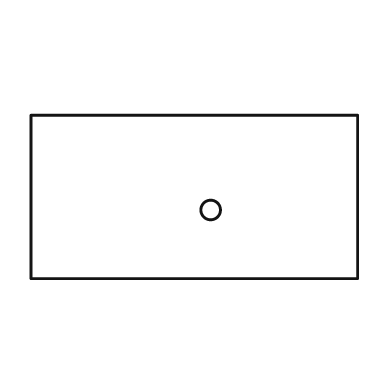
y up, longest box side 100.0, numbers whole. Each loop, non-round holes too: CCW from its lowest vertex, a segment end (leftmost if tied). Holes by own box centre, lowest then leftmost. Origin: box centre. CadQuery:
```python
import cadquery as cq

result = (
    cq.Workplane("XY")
    .moveTo(-50.0, -25.0)
    .lineTo(50.0, -25.0)
    .lineTo(50.0, 25.0)
    .lineTo(-50.0, 25.0)
    .close()
    .moveTo(5.0, -4.0)
    .circle(3.0)
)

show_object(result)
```